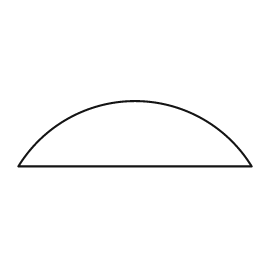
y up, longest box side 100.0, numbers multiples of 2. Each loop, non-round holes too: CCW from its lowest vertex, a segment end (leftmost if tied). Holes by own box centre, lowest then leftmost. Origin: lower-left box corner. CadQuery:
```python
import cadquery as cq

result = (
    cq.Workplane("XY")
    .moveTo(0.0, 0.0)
    .lineTo(100.0, 0.0)
    .threePointArc((50.0, 28.0), (0.0, 0.0))
    .close()
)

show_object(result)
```